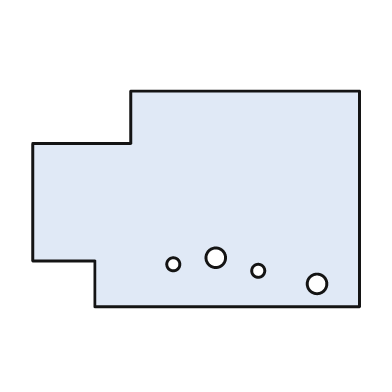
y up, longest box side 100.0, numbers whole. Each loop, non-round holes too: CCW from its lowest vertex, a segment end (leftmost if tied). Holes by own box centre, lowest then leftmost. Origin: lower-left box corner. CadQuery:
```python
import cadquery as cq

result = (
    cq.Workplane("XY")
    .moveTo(19.0, 0.0)
    .lineTo(100.0, 0.0)
    .lineTo(100.0, 66.0)
    .lineTo(30.0, 66.0)
    .lineTo(30.0, 50.0)
    .lineTo(0.0, 50.0)
    .lineTo(0.0, 14.0)
    .lineTo(19.0, 14.0)
    .close()
    .moveTo(87.0, 7.0)
    .circle(3.0)
    .moveTo(69.0, 11.0)
    .circle(2.0)
    .moveTo(43.0, 13.0)
    .circle(2.0)
    .moveTo(56.0, 15.0)
    .circle(3.0)
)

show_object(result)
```